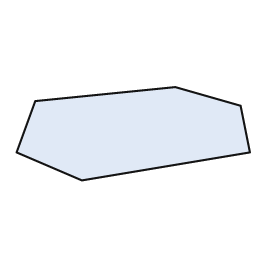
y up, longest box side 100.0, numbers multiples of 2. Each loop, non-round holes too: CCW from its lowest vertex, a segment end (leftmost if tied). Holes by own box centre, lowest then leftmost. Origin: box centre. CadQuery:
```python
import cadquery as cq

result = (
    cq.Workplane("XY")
    .moveTo(-22.0, -20.0)
    .lineTo(50.0, -8.0)
    .lineTo(46.0, 12.0)
    .lineTo(18.0, 20.0)
    .lineTo(-42.0, 14.0)
    .lineTo(-50.0, -8.0)
    .close()
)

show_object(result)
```